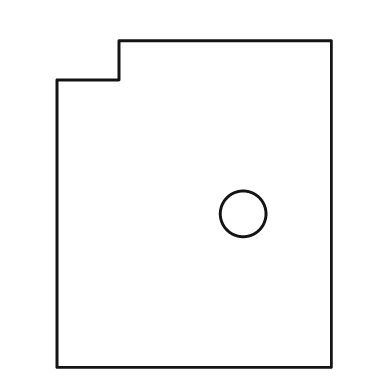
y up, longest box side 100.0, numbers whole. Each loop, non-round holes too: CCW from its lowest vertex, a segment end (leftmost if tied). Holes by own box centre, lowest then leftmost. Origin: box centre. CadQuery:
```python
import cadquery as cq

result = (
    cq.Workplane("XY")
    .moveTo(-42.0, -50.0)
    .lineTo(42.0, -50.0)
    .lineTo(42.0, 50.0)
    .lineTo(-23.0, 50.0)
    .lineTo(-23.0, 38.0)
    .lineTo(-42.0, 38.0)
    .close()
    .moveTo(15.0, -3.0)
    .circle(7.0)
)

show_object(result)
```